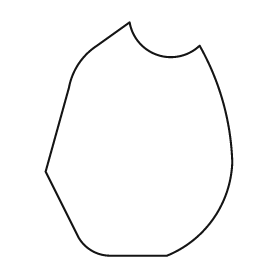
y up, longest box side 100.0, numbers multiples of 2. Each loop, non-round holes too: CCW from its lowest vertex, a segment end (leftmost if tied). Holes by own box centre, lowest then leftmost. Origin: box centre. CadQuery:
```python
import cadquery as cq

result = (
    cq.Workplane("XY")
    .moveTo(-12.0, -50.0)
    .lineTo(12.0, -50.0)
    .threePointArc((32.0, -34.0), (40.0, -10.0))
    .threePointArc((36.0, 16.0), (26.0, 40.0))
    .threePointArc((8.0, 36.0), (-4.0, 50.0))
    .lineTo(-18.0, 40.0)
    .threePointArc((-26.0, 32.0), (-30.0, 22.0))
    .lineTo(-40.0, -14.0)
    .lineTo(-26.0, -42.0)
    .threePointArc((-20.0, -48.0), (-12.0, -50.0))
    .close()
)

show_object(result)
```